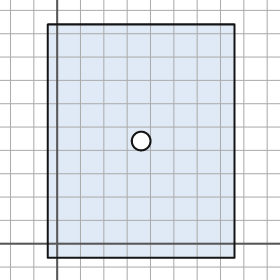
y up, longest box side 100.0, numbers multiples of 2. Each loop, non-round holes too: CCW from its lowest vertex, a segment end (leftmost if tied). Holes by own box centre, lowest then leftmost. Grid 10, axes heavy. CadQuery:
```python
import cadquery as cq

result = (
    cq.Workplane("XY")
    .moveTo(-4.0, -6.0)
    .lineTo(76.0, -6.0)
    .lineTo(76.0, 94.0)
    .lineTo(-4.0, 94.0)
    .close()
    .moveTo(36.0, 44.0)
    .circle(4.0)
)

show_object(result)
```